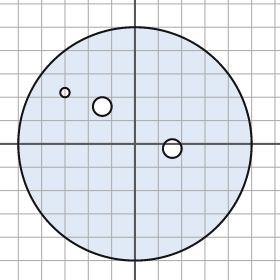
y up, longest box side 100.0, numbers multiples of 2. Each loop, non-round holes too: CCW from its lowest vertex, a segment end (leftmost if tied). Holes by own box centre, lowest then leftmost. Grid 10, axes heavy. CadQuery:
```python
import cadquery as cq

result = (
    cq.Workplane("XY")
    .moveTo(0.0, 0.0)
    .circle(50.0)
    .moveTo(16.0, -2.0)
    .circle(4.0)
    .moveTo(-14.0, 16.0)
    .circle(4.0)
    .moveTo(-30.0, 22.0)
    .circle(2.0)
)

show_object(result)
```